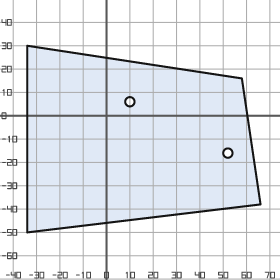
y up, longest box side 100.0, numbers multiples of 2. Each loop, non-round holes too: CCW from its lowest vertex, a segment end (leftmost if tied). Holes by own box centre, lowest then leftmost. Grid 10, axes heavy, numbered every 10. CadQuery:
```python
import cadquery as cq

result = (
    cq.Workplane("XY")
    .moveTo(-34.0, -50.0)
    .lineTo(66.0, -38.0)
    .lineTo(58.0, 16.0)
    .lineTo(-34.0, 30.0)
    .close()
    .moveTo(52.0, -16.0)
    .circle(2.0)
    .moveTo(10.0, 6.0)
    .circle(2.0)
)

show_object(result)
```